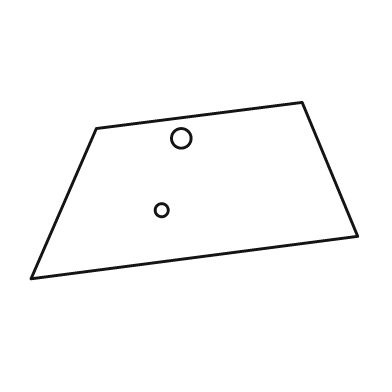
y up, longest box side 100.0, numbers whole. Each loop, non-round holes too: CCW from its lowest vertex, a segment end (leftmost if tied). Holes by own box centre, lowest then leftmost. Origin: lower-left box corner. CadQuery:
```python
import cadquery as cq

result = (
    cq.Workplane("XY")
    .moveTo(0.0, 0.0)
    .lineTo(100.0, 13.0)
    .lineTo(83.0, 54.0)
    .lineTo(20.0, 46.0)
    .close()
    .moveTo(40.0, 21.0)
    .circle(2.0)
    .moveTo(46.0, 43.0)
    .circle(3.0)
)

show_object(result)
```